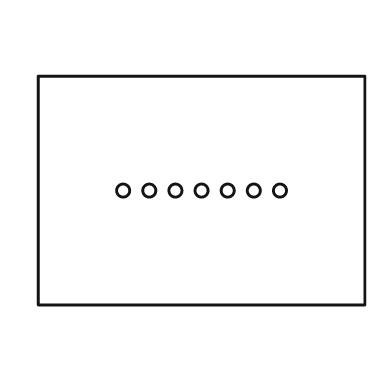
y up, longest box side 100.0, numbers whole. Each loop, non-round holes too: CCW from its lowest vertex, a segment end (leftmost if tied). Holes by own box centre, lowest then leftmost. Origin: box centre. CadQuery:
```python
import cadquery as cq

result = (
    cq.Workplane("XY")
    .moveTo(-50.0, -35.0)
    .lineTo(50.0, -35.0)
    .lineTo(50.0, 35.0)
    .lineTo(-50.0, 35.0)
    .close()
    .moveTo(-24.0, 0.0)
    .circle(2.0)
    .moveTo(-16.0, 0.0)
    .circle(2.0)
    .moveTo(-8.0, 0.0)
    .circle(2.0)
    .moveTo(0.0, 0.0)
    .circle(2.0)
    .moveTo(8.0, 0.0)
    .circle(2.0)
    .moveTo(16.0, 0.0)
    .circle(2.0)
    .moveTo(24.0, 0.0)
    .circle(2.0)
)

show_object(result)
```